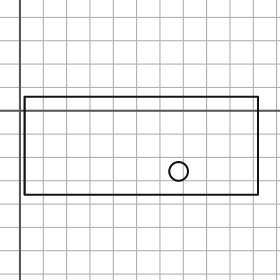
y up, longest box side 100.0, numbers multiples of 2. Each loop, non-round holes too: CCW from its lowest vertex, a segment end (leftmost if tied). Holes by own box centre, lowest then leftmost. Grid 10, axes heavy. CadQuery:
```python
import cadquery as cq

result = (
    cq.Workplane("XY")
    .moveTo(2.0, -36.0)
    .lineTo(102.0, -36.0)
    .lineTo(102.0, 6.0)
    .lineTo(2.0, 6.0)
    .close()
    .moveTo(68.0, -26.0)
    .circle(4.0)
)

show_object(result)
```